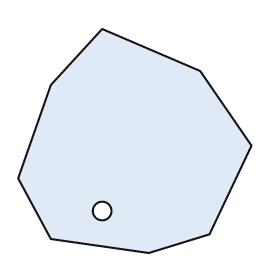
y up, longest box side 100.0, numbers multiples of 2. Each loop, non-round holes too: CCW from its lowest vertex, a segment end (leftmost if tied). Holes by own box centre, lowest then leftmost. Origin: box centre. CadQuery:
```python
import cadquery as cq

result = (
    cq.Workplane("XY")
    .moveTo(6.0, -48.0)
    .lineTo(32.0, -40.0)
    .lineTo(50.0, -2.0)
    .lineTo(28.0, 30.0)
    .lineTo(-14.0, 48.0)
    .lineTo(-36.0, 24.0)
    .lineTo(-50.0, -16.0)
    .lineTo(-36.0, -42.0)
    .close()
    .moveTo(-14.0, -30.0)
    .circle(4.0)
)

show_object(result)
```